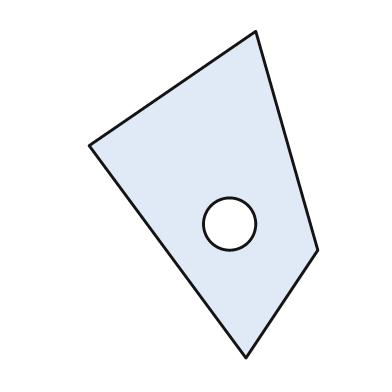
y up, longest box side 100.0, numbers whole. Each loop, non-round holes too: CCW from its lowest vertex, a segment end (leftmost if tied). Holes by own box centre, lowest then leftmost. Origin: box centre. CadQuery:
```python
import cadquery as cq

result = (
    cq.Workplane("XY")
    .moveTo(13.0, -50.0)
    .lineTo(35.0, -17.0)
    .lineTo(16.0, 50.0)
    .lineTo(-35.0, 15.0)
    .close()
    .moveTo(8.0, -9.0)
    .circle(8.0)
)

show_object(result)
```